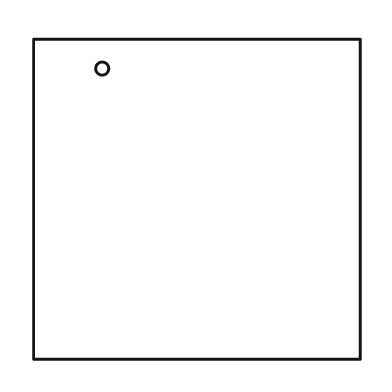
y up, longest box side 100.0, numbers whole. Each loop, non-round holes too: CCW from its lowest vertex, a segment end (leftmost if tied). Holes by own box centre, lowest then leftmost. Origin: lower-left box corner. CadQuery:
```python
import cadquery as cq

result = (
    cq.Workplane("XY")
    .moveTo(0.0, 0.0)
    .lineTo(100.0, 0.0)
    .lineTo(100.0, 98.0)
    .lineTo(0.0, 98.0)
    .close()
    .moveTo(21.0, 89.0)
    .circle(2.0)
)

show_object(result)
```